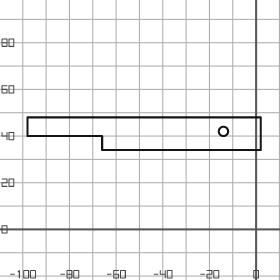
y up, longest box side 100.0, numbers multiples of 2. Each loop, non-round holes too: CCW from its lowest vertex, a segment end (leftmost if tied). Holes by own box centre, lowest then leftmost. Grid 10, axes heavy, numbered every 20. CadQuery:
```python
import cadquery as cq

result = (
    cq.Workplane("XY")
    .moveTo(-66.0, 34.0)
    .lineTo(2.0, 34.0)
    .lineTo(2.0, 48.0)
    .lineTo(-98.0, 48.0)
    .lineTo(-98.0, 40.0)
    .lineTo(-66.0, 40.0)
    .close()
    .moveTo(-14.0, 42.0)
    .circle(2.0)
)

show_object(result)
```